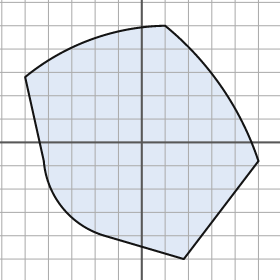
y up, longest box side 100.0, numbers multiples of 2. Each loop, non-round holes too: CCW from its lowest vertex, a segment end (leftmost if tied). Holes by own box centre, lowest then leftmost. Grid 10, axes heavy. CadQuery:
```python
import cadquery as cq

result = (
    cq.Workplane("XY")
    .moveTo(18.0, -50.0)
    .lineTo(50.0, -8.0)
    .threePointArc((34.0, 24.0), (10.0, 50.0))
    .threePointArc((-22.0, 44.0), (-50.0, 28.0))
    .lineTo(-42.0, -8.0)
    .threePointArc((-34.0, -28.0), (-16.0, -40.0))
    .close()
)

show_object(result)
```